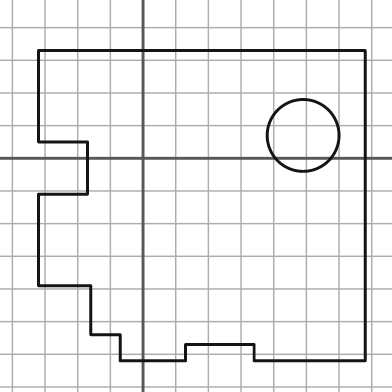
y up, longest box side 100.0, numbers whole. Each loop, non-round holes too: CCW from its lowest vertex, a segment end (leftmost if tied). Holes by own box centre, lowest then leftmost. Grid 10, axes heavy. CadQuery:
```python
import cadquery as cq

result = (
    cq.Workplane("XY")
    .moveTo(-7.0, -62.0)
    .lineTo(13.0, -62.0)
    .lineTo(13.0, -57.0)
    .lineTo(34.0, -57.0)
    .lineTo(34.0, -62.0)
    .lineTo(68.0, -62.0)
    .lineTo(68.0, 33.0)
    .lineTo(-32.0, 33.0)
    .lineTo(-32.0, 5.0)
    .lineTo(-17.0, 5.0)
    .lineTo(-17.0, -11.0)
    .lineTo(-32.0, -11.0)
    .lineTo(-32.0, -39.0)
    .lineTo(-16.0, -39.0)
    .lineTo(-16.0, -54.0)
    .lineTo(-7.0, -54.0)
    .close()
    .moveTo(49.0, 7.0)
    .circle(11.0)
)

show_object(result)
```